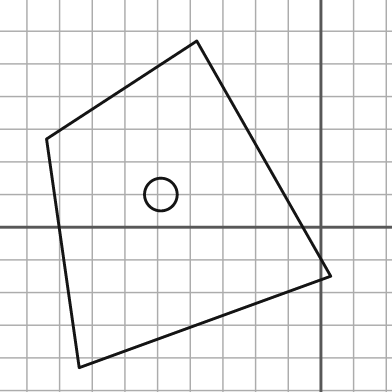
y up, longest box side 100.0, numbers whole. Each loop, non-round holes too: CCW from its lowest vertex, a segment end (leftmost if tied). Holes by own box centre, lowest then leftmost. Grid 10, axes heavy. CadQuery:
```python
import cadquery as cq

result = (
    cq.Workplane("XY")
    .moveTo(-74.0, -43.0)
    .lineTo(3.0, -15.0)
    .lineTo(-38.0, 57.0)
    .lineTo(-84.0, 27.0)
    .close()
    .moveTo(-49.0, 10.0)
    .circle(5.0)
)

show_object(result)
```